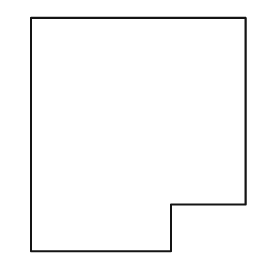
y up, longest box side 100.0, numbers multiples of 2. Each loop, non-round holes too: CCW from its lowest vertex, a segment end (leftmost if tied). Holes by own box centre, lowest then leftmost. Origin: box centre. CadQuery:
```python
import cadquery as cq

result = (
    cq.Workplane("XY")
    .moveTo(-46.0, -50.0)
    .lineTo(14.0, -50.0)
    .lineTo(14.0, -30.0)
    .lineTo(46.0, -30.0)
    .lineTo(46.0, 50.0)
    .lineTo(-46.0, 50.0)
    .close()
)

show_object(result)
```